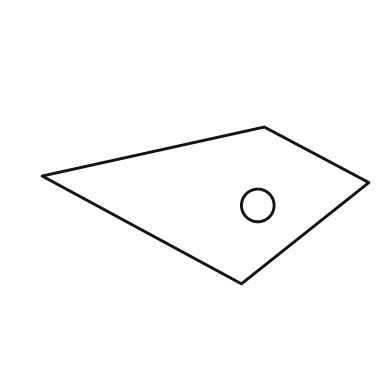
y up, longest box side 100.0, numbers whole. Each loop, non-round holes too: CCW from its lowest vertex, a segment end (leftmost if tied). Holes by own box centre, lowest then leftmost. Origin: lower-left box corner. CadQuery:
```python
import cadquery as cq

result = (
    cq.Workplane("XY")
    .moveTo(61.0, 0.0)
    .lineTo(100.0, 31.0)
    .lineTo(68.0, 48.0)
    .lineTo(0.0, 33.0)
    .close()
    .moveTo(66.0, 24.0)
    .circle(5.0)
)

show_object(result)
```